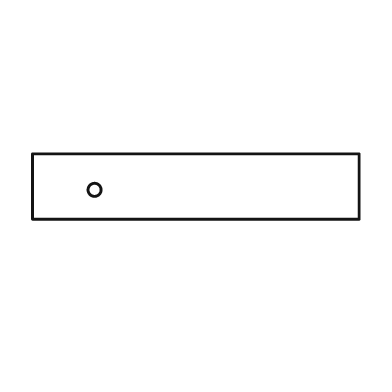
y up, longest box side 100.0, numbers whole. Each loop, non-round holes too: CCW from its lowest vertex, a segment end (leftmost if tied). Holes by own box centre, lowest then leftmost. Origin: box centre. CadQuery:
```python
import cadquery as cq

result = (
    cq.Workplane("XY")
    .moveTo(-50.0, -10.0)
    .lineTo(50.0, -10.0)
    .lineTo(50.0, 10.0)
    .lineTo(-50.0, 10.0)
    .close()
    .moveTo(-31.0, -1.0)
    .circle(2.0)
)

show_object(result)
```